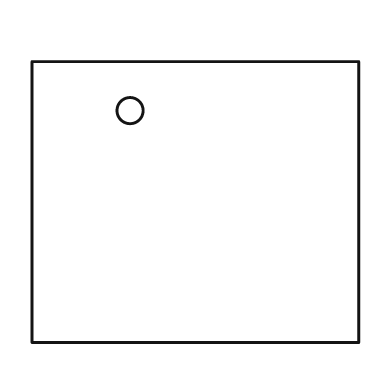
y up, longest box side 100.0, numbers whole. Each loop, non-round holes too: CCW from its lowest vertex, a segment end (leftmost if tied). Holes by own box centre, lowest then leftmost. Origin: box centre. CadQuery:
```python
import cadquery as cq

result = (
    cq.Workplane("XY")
    .moveTo(-50.0, -43.0)
    .lineTo(50.0, -43.0)
    .lineTo(50.0, 43.0)
    .lineTo(-50.0, 43.0)
    .close()
    .moveTo(-20.0, 28.0)
    .circle(4.0)
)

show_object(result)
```